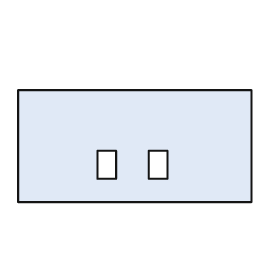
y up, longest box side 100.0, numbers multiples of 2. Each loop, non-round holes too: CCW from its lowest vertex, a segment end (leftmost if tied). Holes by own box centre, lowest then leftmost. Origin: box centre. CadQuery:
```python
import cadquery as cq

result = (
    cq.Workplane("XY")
    .moveTo(-50.0, -24.0)
    .lineTo(50.0, -24.0)
    .lineTo(50.0, 24.0)
    .lineTo(-50.0, 24.0)
    .close()
    .moveTo(-16.0, -14.0)
    .lineTo(-8.0, -14.0)
    .lineTo(-8.0, -2.0)
    .lineTo(-16.0, -2.0)
    .close()
    .moveTo(6.0, -14.0)
    .lineTo(14.0, -14.0)
    .lineTo(14.0, -2.0)
    .lineTo(6.0, -2.0)
    .close()
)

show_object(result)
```